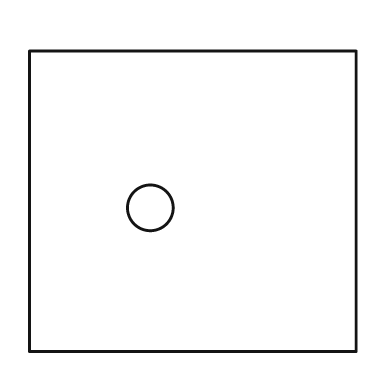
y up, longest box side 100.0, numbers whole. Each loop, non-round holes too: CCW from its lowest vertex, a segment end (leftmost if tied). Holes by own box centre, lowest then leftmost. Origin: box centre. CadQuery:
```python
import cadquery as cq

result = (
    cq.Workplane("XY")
    .moveTo(-50.0, -46.0)
    .lineTo(50.0, -46.0)
    .lineTo(50.0, 46.0)
    .lineTo(-50.0, 46.0)
    .close()
    .moveTo(-13.0, -2.0)
    .circle(7.0)
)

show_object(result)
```